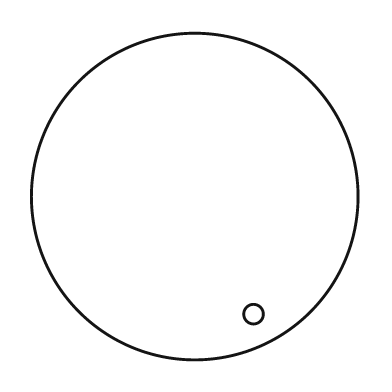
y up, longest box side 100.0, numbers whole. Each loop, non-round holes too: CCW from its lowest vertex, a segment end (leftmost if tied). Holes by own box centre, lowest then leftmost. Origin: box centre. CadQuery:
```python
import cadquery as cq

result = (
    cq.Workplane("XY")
    .moveTo(0.0, 0.0)
    .circle(50.0)
    .moveTo(18.0, -36.0)
    .circle(3.0)
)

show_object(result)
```